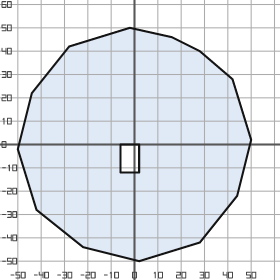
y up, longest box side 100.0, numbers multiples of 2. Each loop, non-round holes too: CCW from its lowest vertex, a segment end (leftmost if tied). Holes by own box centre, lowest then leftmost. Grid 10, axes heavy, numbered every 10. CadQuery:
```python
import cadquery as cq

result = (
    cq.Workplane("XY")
    .moveTo(2.0, -50.0)
    .lineTo(28.0, -42.0)
    .lineTo(44.0, -22.0)
    .lineTo(50.0, 2.0)
    .lineTo(42.0, 28.0)
    .lineTo(28.0, 40.0)
    .lineTo(16.0, 46.0)
    .lineTo(-2.0, 50.0)
    .lineTo(-28.0, 42.0)
    .lineTo(-44.0, 22.0)
    .lineTo(-50.0, -2.0)
    .lineTo(-42.0, -28.0)
    .lineTo(-22.0, -44.0)
    .close()
    .moveTo(-6.0, -12.0)
    .lineTo(2.0, -12.0)
    .lineTo(2.0, 0.0)
    .lineTo(-6.0, 0.0)
    .close()
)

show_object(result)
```